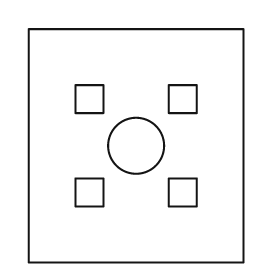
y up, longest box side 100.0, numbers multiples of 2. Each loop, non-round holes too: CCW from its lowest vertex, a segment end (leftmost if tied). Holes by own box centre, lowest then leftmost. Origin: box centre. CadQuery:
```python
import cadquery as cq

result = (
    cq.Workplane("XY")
    .moveTo(-46.0, -50.0)
    .lineTo(46.0, -50.0)
    .lineTo(46.0, 50.0)
    .lineTo(-46.0, 50.0)
    .close()
    .moveTo(-26.0, -26.0)
    .lineTo(-14.0, -26.0)
    .lineTo(-14.0, -14.0)
    .lineTo(-26.0, -14.0)
    .close()
    .moveTo(14.0, -26.0)
    .lineTo(26.0, -26.0)
    .lineTo(26.0, -14.0)
    .lineTo(14.0, -14.0)
    .close()
    .moveTo(0.0, 0.0)
    .circle(12.0)
    .moveTo(-26.0, 14.0)
    .lineTo(-14.0, 14.0)
    .lineTo(-14.0, 26.0)
    .lineTo(-26.0, 26.0)
    .close()
    .moveTo(14.0, 14.0)
    .lineTo(26.0, 14.0)
    .lineTo(26.0, 26.0)
    .lineTo(14.0, 26.0)
    .close()
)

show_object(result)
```